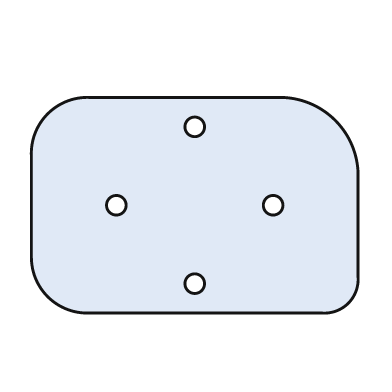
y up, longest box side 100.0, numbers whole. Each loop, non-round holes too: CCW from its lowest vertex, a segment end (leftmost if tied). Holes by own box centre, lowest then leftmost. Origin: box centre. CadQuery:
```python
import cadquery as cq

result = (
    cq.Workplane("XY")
    .moveTo(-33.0, -33.0)
    .lineTo(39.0, -33.0)
    .threePointArc((47.0, -30.0), (50.0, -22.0))
    .lineTo(50.0, 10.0)
    .threePointArc((43.0, 26.0), (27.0, 33.0))
    .lineTo(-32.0, 33.0)
    .threePointArc((-45.0, 28.0), (-50.0, 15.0))
    .lineTo(-50.0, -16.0)
    .threePointArc((-45.0, -28.0), (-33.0, -33.0))
    .close()
    .moveTo(0.0, -24.0)
    .circle(3.0)
    .moveTo(-24.0, 0.0)
    .circle(3.0)
    .moveTo(24.0, 0.0)
    .circle(3.0)
    .moveTo(0.0, 24.0)
    .circle(3.0)
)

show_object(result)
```